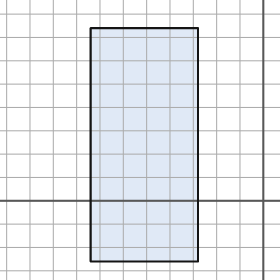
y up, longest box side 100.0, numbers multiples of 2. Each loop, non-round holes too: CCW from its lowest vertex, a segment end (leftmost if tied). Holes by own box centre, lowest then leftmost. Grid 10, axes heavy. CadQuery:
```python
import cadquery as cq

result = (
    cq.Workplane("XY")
    .moveTo(-74.0, -26.0)
    .lineTo(-28.0, -26.0)
    .lineTo(-28.0, 74.0)
    .lineTo(-74.0, 74.0)
    .close()
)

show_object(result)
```